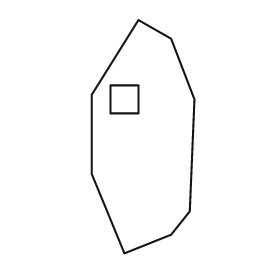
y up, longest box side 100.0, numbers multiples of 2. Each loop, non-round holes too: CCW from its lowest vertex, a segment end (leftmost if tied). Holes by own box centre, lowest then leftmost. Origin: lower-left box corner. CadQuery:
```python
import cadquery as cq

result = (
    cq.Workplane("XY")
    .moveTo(14.0, 0.0)
    .lineTo(34.0, 8.0)
    .lineTo(42.0, 18.0)
    .lineTo(44.0, 66.0)
    .lineTo(34.0, 92.0)
    .lineTo(20.0, 100.0)
    .lineTo(0.0, 68.0)
    .lineTo(0.0, 34.0)
    .close()
    .moveTo(8.0, 60.0)
    .lineTo(20.0, 60.0)
    .lineTo(20.0, 72.0)
    .lineTo(8.0, 72.0)
    .close()
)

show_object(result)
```